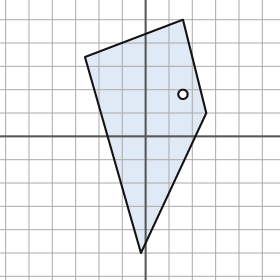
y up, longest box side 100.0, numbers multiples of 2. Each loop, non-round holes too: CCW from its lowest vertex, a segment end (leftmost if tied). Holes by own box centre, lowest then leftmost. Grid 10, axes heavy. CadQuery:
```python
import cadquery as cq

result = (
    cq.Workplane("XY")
    .moveTo(-2.0, -50.0)
    .lineTo(26.0, 10.0)
    .lineTo(16.0, 50.0)
    .lineTo(-26.0, 34.0)
    .close()
    .moveTo(16.0, 18.0)
    .circle(2.0)
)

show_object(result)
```